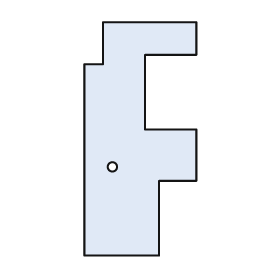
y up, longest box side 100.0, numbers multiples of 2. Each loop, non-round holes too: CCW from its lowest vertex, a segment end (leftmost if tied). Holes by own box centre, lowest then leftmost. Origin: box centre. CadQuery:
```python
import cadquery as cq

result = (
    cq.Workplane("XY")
    .moveTo(-24.0, -50.0)
    .lineTo(8.0, -50.0)
    .lineTo(8.0, -18.0)
    .lineTo(24.0, -18.0)
    .lineTo(24.0, 4.0)
    .lineTo(2.0, 4.0)
    .lineTo(2.0, 36.0)
    .lineTo(24.0, 36.0)
    .lineTo(24.0, 50.0)
    .lineTo(-16.0, 50.0)
    .lineTo(-16.0, 32.0)
    .lineTo(-24.0, 32.0)
    .close()
    .moveTo(-12.0, -12.0)
    .circle(2.0)
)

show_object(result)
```